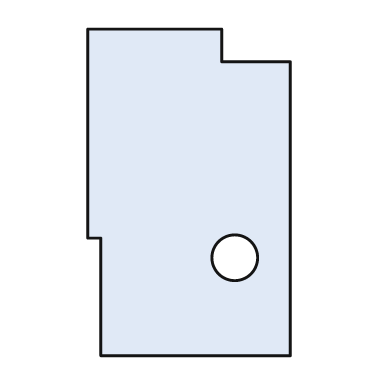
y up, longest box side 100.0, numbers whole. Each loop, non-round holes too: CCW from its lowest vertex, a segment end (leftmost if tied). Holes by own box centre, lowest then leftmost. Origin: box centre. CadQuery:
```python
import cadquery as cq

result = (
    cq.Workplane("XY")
    .moveTo(-27.0, -50.0)
    .lineTo(31.0, -50.0)
    .lineTo(31.0, 40.0)
    .lineTo(10.0, 40.0)
    .lineTo(10.0, 50.0)
    .lineTo(-31.0, 50.0)
    .lineTo(-31.0, -14.0)
    .lineTo(-27.0, -14.0)
    .close()
    .moveTo(14.0, -20.0)
    .circle(7.0)
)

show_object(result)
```